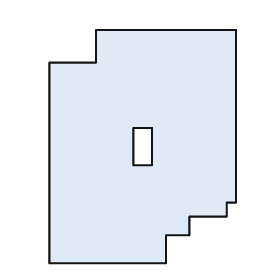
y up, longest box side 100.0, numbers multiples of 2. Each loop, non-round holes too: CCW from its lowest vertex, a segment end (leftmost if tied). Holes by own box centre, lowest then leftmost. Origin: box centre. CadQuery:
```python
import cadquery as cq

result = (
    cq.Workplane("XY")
    .moveTo(-40.0, -50.0)
    .lineTo(10.0, -50.0)
    .lineTo(10.0, -38.0)
    .lineTo(20.0, -38.0)
    .lineTo(20.0, -30.0)
    .lineTo(36.0, -30.0)
    .lineTo(36.0, -24.0)
    .lineTo(40.0, -24.0)
    .lineTo(40.0, 50.0)
    .lineTo(-20.0, 50.0)
    .lineTo(-20.0, 36.0)
    .lineTo(-40.0, 36.0)
    .close()
    .moveTo(-4.0, -8.0)
    .lineTo(4.0, -8.0)
    .lineTo(4.0, 8.0)
    .lineTo(-4.0, 8.0)
    .close()
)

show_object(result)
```